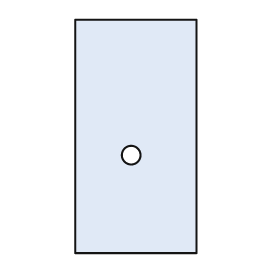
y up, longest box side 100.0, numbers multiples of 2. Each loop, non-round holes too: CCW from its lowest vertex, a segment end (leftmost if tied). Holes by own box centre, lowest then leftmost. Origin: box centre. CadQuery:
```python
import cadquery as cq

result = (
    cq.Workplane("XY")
    .moveTo(-26.0, -50.0)
    .lineTo(26.0, -50.0)
    .lineTo(26.0, 50.0)
    .lineTo(-26.0, 50.0)
    .close()
    .moveTo(-2.0, -8.0)
    .circle(4.0)
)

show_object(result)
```